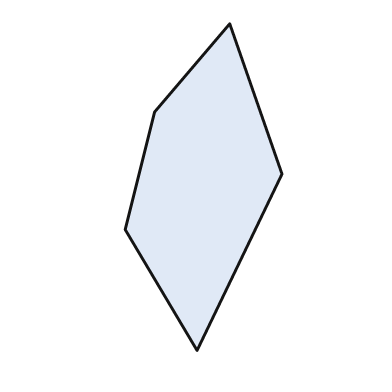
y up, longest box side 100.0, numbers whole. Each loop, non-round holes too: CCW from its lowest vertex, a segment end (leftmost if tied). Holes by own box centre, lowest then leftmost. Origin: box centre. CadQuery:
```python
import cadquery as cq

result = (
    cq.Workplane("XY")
    .moveTo(-2.0, -50.0)
    .lineTo(24.0, 4.0)
    .lineTo(8.0, 50.0)
    .lineTo(-15.0, 23.0)
    .lineTo(-24.0, -13.0)
    .close()
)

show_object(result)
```